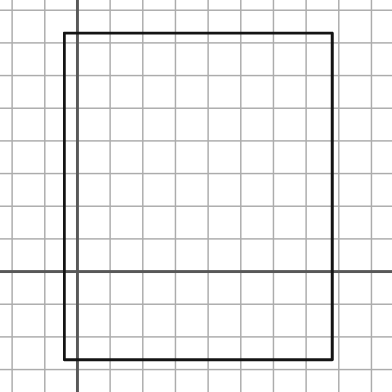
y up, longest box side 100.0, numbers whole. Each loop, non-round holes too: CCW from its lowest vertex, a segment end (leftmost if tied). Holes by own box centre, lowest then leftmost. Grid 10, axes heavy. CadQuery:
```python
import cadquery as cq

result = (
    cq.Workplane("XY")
    .moveTo(-4.0, -27.0)
    .lineTo(78.0, -27.0)
    .lineTo(78.0, 73.0)
    .lineTo(-4.0, 73.0)
    .close()
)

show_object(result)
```